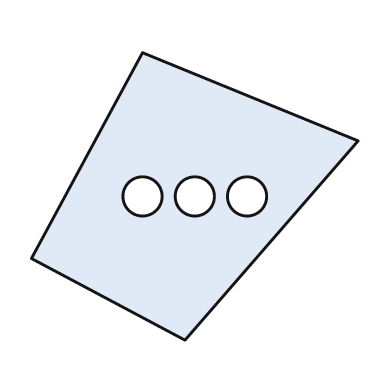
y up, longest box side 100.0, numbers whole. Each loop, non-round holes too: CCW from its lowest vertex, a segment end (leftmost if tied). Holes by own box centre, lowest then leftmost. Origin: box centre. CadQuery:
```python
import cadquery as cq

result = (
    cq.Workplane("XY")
    .moveTo(-3.0, -44.0)
    .lineTo(50.0, 17.0)
    .lineTo(-16.0, 44.0)
    .lineTo(-50.0, -19.0)
    .close()
    .moveTo(-16.0, 0.0)
    .circle(6.0)
    .moveTo(0.0, 0.0)
    .circle(6.0)
    .moveTo(16.0, 0.0)
    .circle(6.0)
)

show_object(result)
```